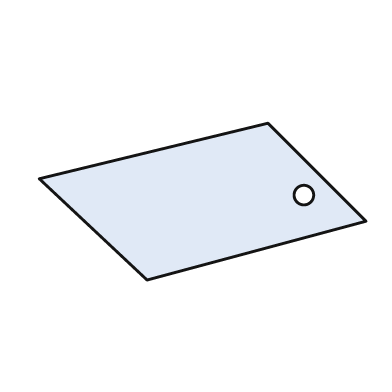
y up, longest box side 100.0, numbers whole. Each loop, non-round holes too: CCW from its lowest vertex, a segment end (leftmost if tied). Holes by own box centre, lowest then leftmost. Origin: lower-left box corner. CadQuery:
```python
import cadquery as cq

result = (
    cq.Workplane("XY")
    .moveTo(33.0, 0.0)
    .lineTo(100.0, 18.0)
    .lineTo(70.0, 48.0)
    .lineTo(0.0, 31.0)
    .close()
    .moveTo(81.0, 26.0)
    .circle(3.0)
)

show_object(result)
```